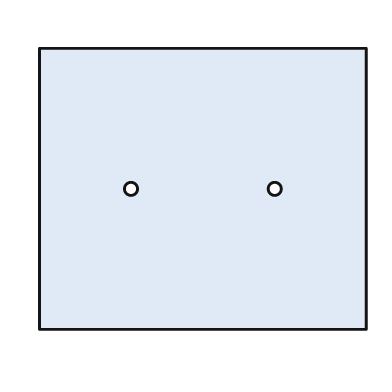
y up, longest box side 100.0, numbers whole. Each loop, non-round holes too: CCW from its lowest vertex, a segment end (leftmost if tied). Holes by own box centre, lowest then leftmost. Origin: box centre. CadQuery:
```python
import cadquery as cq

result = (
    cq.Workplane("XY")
    .moveTo(-50.0, -43.0)
    .lineTo(50.0, -43.0)
    .lineTo(50.0, 43.0)
    .lineTo(-50.0, 43.0)
    .close()
    .moveTo(-22.0, 0.0)
    .circle(2.0)
    .moveTo(22.0, 0.0)
    .circle(2.0)
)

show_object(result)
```